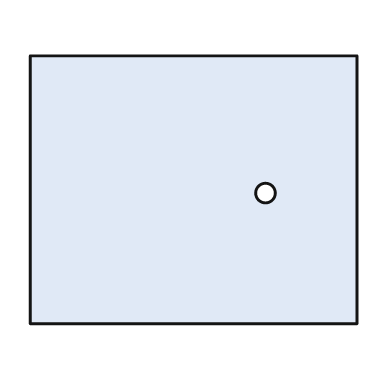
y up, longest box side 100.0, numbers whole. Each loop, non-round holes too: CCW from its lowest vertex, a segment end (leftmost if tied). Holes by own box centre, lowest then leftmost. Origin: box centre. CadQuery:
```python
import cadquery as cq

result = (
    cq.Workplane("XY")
    .moveTo(-50.0, -41.0)
    .lineTo(50.0, -41.0)
    .lineTo(50.0, 41.0)
    .lineTo(-50.0, 41.0)
    .close()
    .moveTo(22.0, -1.0)
    .circle(3.0)
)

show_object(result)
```